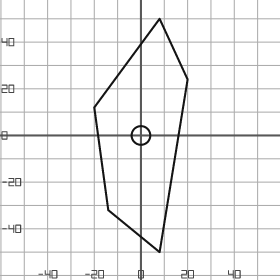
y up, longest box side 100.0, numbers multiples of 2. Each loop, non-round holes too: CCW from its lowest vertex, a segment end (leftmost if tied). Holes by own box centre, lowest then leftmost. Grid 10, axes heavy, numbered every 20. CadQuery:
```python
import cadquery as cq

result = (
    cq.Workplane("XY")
    .moveTo(8.0, -50.0)
    .lineTo(20.0, 24.0)
    .lineTo(8.0, 50.0)
    .lineTo(-20.0, 12.0)
    .lineTo(-14.0, -32.0)
    .close()
    .moveTo(0.0, 0.0)
    .circle(4.0)
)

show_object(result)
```